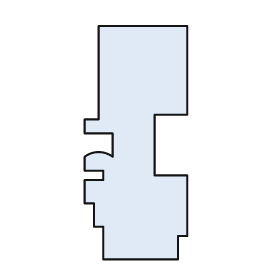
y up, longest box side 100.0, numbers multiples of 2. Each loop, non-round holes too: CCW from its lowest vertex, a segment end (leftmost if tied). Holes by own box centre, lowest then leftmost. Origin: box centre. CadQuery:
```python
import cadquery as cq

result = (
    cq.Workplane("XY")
    .moveTo(-14.0, -50.0)
    .lineTo(18.0, -50.0)
    .lineTo(18.0, -40.0)
    .lineTo(22.0, -40.0)
    .lineTo(22.0, -14.0)
    .lineTo(8.0, -14.0)
    .lineTo(8.0, 12.0)
    .lineTo(22.0, 12.0)
    .lineTo(22.0, 50.0)
    .lineTo(-16.0, 50.0)
    .lineTo(-16.0, 10.0)
    .lineTo(-22.0, 10.0)
    .lineTo(-22.0, 4.0)
    .lineTo(-10.0, 4.0)
    .lineTo(-10.0, -6.0)
    .threePointArc((-16.0, -4.0), (-22.0, -6.0))
    .lineTo(-22.0, -12.0)
    .lineTo(-14.0, -12.0)
    .lineTo(-14.0, -16.0)
    .lineTo(-22.0, -16.0)
    .lineTo(-22.0, -26.0)
    .lineTo(-18.0, -26.0)
    .lineTo(-18.0, -36.0)
    .lineTo(-14.0, -36.0)
    .close()
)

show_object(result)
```